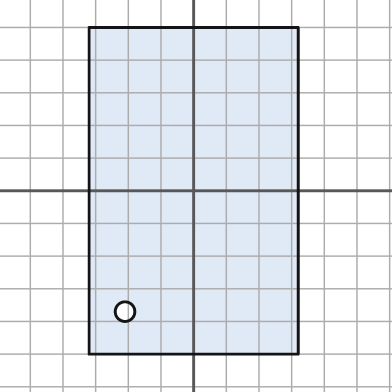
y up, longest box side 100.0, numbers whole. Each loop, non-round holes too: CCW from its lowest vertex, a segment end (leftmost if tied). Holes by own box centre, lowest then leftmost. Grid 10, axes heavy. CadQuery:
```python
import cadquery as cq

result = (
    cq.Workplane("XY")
    .moveTo(-32.0, -50.0)
    .lineTo(32.0, -50.0)
    .lineTo(32.0, 50.0)
    .lineTo(-32.0, 50.0)
    .close()
    .moveTo(-21.0, -37.0)
    .circle(3.0)
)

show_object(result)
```